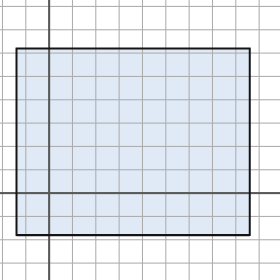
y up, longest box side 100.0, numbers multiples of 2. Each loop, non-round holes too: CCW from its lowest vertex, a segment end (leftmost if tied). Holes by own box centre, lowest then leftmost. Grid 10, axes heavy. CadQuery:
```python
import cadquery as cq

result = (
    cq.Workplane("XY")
    .moveTo(-14.0, -18.0)
    .lineTo(86.0, -18.0)
    .lineTo(86.0, 62.0)
    .lineTo(-14.0, 62.0)
    .close()
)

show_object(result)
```